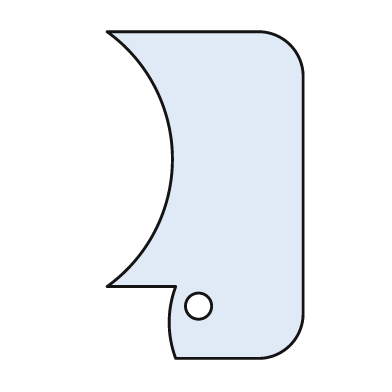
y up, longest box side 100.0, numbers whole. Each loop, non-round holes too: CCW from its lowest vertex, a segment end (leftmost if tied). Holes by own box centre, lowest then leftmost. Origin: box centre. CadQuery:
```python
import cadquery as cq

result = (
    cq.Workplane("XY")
    .moveTo(-9.0, -50.0)
    .lineTo(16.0, -50.0)
    .threePointArc((26.0, -46.0), (30.0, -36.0))
    .lineTo(30.0, 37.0)
    .threePointArc((26.0, 46.0), (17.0, 50.0))
    .lineTo(-30.0, 50.0)
    .threePointArc((-10.0, 11.0), (-30.0, -28.0))
    .lineTo(-9.0, -28.0)
    .threePointArc((-11.0, -39.0), (-9.0, -50.0))
    .close()
    .moveTo(-2.0, -34.0)
    .circle(4.0)
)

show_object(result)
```